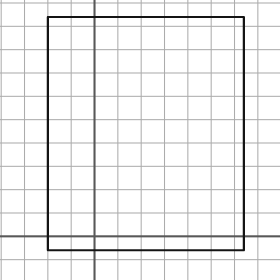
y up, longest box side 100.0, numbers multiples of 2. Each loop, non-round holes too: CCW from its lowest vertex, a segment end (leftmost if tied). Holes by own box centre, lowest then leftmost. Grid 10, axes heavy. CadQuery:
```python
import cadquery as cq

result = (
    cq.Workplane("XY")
    .moveTo(-20.0, -6.0)
    .lineTo(64.0, -6.0)
    .lineTo(64.0, 94.0)
    .lineTo(-20.0, 94.0)
    .close()
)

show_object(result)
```